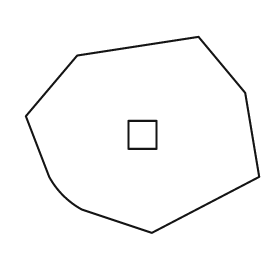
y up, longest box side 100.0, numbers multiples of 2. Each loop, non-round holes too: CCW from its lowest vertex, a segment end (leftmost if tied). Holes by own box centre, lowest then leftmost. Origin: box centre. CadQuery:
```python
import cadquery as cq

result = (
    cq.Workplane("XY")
    .moveTo(4.0, -42.0)
    .lineTo(50.0, -18.0)
    .lineTo(44.0, 18.0)
    .lineTo(24.0, 42.0)
    .lineTo(-28.0, 34.0)
    .lineTo(-50.0, 8.0)
    .lineTo(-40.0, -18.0)
    .threePointArc((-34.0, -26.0), (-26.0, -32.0))
    .close()
    .moveTo(-6.0, -6.0)
    .lineTo(6.0, -6.0)
    .lineTo(6.0, 6.0)
    .lineTo(-6.0, 6.0)
    .close()
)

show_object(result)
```